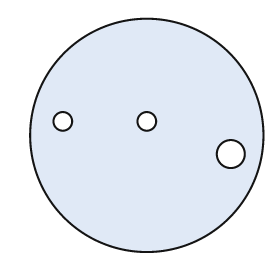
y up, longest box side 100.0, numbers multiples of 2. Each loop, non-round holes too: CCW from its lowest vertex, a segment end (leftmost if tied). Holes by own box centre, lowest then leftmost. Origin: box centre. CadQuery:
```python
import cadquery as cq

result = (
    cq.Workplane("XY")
    .moveTo(0.0, 0.0)
    .circle(50.0)
    .moveTo(36.0, -8.0)
    .circle(6.0)
    .moveTo(-36.0, 6.0)
    .circle(4.0)
    .moveTo(0.0, 6.0)
    .circle(4.0)
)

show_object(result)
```